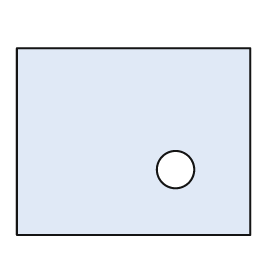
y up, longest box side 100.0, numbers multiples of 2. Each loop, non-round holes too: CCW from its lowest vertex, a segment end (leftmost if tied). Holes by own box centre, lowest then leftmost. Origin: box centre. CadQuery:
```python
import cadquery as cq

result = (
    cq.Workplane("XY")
    .moveTo(-50.0, -40.0)
    .lineTo(50.0, -40.0)
    .lineTo(50.0, 40.0)
    .lineTo(-50.0, 40.0)
    .close()
    .moveTo(18.0, -12.0)
    .circle(8.0)
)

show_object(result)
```